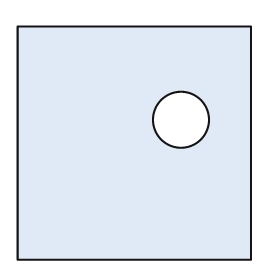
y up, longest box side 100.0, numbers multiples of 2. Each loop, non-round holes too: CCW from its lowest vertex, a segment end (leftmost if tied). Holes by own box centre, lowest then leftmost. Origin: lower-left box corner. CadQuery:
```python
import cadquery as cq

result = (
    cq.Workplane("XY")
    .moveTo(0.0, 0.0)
    .lineTo(100.0, 0.0)
    .lineTo(100.0, 100.0)
    .lineTo(0.0, 100.0)
    .close()
    .moveTo(70.0, 60.0)
    .circle(12.0)
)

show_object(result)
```